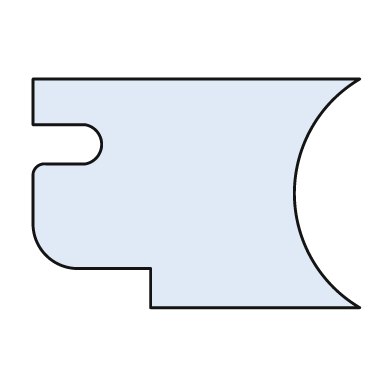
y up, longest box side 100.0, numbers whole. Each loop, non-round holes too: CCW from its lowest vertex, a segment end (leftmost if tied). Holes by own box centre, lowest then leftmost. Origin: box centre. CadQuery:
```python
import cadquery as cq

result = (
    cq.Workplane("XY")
    .moveTo(-14.0, -35.0)
    .lineTo(50.0, -35.0)
    .threePointArc((30.0, 0.0), (50.0, 35.0))
    .lineTo(-50.0, 35.0)
    .lineTo(-50.0, 21.0)
    .lineTo(-34.0, 21.0)
    .threePointArc((-29.0, 15.0), (-34.0, 9.0))
    .lineTo(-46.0, 9.0)
    .threePointArc((-49.0, 8.0), (-50.0, 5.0))
    .lineTo(-50.0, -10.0)
    .threePointArc((-46.0, -19.0), (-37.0, -23.0))
    .lineTo(-14.0, -23.0)
    .close()
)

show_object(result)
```